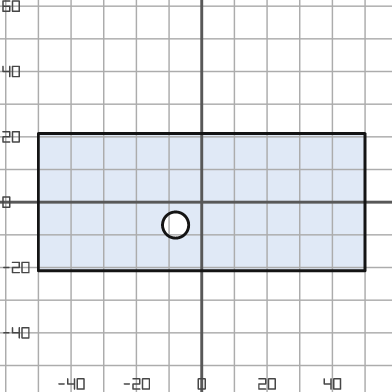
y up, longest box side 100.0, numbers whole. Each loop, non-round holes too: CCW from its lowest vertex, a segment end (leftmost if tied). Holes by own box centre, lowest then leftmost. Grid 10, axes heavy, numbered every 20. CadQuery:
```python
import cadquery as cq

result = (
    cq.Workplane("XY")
    .moveTo(-50.0, -21.0)
    .lineTo(50.0, -21.0)
    .lineTo(50.0, 21.0)
    .lineTo(-50.0, 21.0)
    .close()
    .moveTo(-8.0, -7.0)
    .circle(4.0)
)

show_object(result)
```